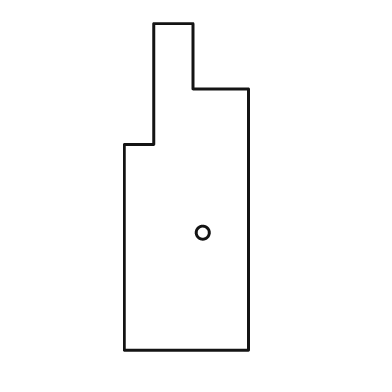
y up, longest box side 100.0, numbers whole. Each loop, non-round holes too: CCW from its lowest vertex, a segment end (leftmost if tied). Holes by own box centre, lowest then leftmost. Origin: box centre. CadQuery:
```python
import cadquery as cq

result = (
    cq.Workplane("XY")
    .moveTo(-19.0, -50.0)
    .lineTo(19.0, -50.0)
    .lineTo(19.0, 30.0)
    .lineTo(2.0, 30.0)
    .lineTo(2.0, 50.0)
    .lineTo(-10.0, 50.0)
    .lineTo(-10.0, 13.0)
    .lineTo(-19.0, 13.0)
    .close()
    .moveTo(5.0, -14.0)
    .circle(2.0)
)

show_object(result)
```